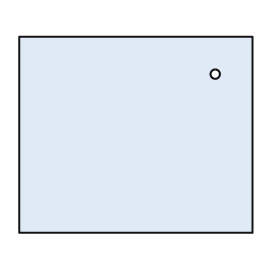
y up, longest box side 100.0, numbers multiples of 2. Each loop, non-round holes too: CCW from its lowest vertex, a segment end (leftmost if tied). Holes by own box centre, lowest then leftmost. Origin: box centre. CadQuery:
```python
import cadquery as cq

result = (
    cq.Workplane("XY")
    .moveTo(-50.0, -42.0)
    .lineTo(50.0, -42.0)
    .lineTo(50.0, 42.0)
    .lineTo(-50.0, 42.0)
    .close()
    .moveTo(34.0, 26.0)
    .circle(2.0)
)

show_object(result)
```